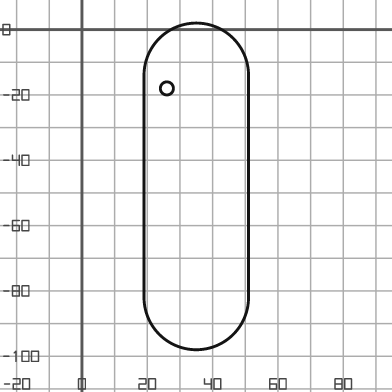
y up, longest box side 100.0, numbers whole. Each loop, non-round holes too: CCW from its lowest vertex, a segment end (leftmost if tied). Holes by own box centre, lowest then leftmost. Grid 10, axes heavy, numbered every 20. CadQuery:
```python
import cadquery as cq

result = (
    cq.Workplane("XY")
    .moveTo(19.0, -82.0)
    .threePointArc((35.0, -98.0), (51.0, -82.0))
    .lineTo(51.0, -14.0)
    .threePointArc((35.0, 2.0), (19.0, -14.0))
    .close()
    .moveTo(26.0, -18.0)
    .circle(2.0)
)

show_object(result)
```